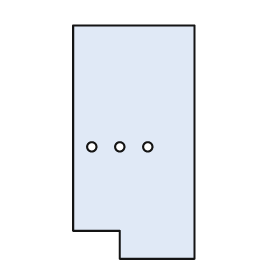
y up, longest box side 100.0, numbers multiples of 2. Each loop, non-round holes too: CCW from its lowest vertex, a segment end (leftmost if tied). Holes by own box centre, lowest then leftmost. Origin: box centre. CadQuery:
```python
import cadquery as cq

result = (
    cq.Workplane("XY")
    .moveTo(-6.0, -50.0)
    .lineTo(26.0, -50.0)
    .lineTo(26.0, 50.0)
    .lineTo(-26.0, 50.0)
    .lineTo(-26.0, -38.0)
    .lineTo(-6.0, -38.0)
    .close()
    .moveTo(-18.0, -2.0)
    .circle(2.0)
    .moveTo(-6.0, -2.0)
    .circle(2.0)
    .moveTo(6.0, -2.0)
    .circle(2.0)
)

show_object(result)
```